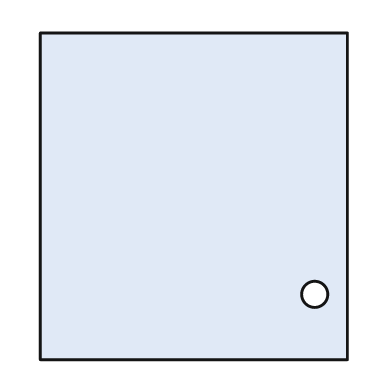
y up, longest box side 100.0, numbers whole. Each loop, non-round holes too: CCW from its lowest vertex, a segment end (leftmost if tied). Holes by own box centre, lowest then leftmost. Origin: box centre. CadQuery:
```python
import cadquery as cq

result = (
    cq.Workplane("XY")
    .moveTo(-47.0, -50.0)
    .lineTo(47.0, -50.0)
    .lineTo(47.0, 50.0)
    .lineTo(-47.0, 50.0)
    .close()
    .moveTo(37.0, -30.0)
    .circle(4.0)
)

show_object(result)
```